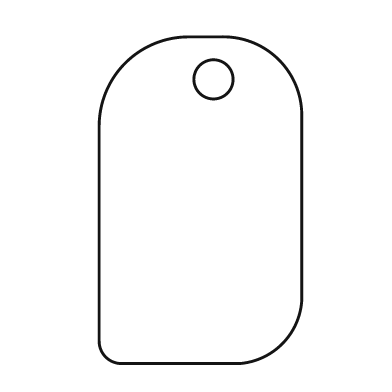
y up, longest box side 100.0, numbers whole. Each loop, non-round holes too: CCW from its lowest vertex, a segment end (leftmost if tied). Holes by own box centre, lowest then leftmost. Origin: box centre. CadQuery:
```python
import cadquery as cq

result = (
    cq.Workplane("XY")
    .moveTo(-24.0, -50.0)
    .lineTo(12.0, -50.0)
    .threePointArc((25.0, -44.0), (31.0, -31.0))
    .lineTo(31.0, 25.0)
    .threePointArc((24.0, 43.0), (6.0, 50.0))
    .lineTo(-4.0, 50.0)
    .threePointArc((-23.0, 42.0), (-31.0, 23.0))
    .lineTo(-31.0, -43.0)
    .threePointArc((-29.0, -48.0), (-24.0, -50.0))
    .close()
    .moveTo(4.0, 37.0)
    .circle(6.0)
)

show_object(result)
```